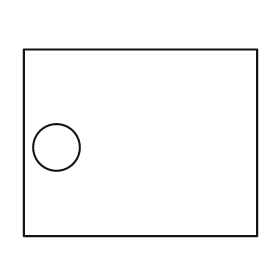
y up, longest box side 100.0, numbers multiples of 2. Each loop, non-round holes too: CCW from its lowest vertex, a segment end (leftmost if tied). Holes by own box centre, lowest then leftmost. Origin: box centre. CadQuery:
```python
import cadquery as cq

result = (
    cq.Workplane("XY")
    .moveTo(-50.0, -40.0)
    .lineTo(50.0, -40.0)
    .lineTo(50.0, 40.0)
    .lineTo(-50.0, 40.0)
    .close()
    .moveTo(-36.0, -2.0)
    .circle(10.0)
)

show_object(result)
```